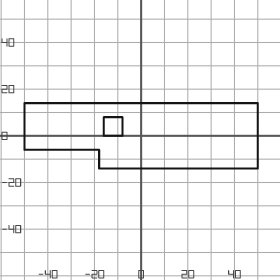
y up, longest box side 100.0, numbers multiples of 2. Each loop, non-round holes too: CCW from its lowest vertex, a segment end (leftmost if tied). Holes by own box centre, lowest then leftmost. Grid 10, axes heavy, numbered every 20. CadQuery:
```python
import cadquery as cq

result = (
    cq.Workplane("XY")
    .moveTo(-18.0, -14.0)
    .lineTo(50.0, -14.0)
    .lineTo(50.0, 14.0)
    .lineTo(-50.0, 14.0)
    .lineTo(-50.0, -6.0)
    .lineTo(-18.0, -6.0)
    .close()
    .moveTo(-16.0, 0.0)
    .lineTo(-8.0, 0.0)
    .lineTo(-8.0, 8.0)
    .lineTo(-16.0, 8.0)
    .close()
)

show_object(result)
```